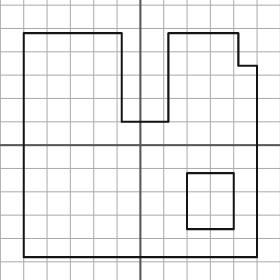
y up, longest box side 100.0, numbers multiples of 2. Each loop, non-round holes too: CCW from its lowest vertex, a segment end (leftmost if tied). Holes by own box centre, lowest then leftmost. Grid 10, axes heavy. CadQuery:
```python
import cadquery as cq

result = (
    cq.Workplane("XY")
    .moveTo(-50.0, -48.0)
    .lineTo(50.0, -48.0)
    .lineTo(50.0, 34.0)
    .lineTo(42.0, 34.0)
    .lineTo(42.0, 48.0)
    .lineTo(12.0, 48.0)
    .lineTo(12.0, 10.0)
    .lineTo(-8.0, 10.0)
    .lineTo(-8.0, 48.0)
    .lineTo(-50.0, 48.0)
    .close()
    .moveTo(20.0, -36.0)
    .lineTo(40.0, -36.0)
    .lineTo(40.0, -12.0)
    .lineTo(20.0, -12.0)
    .close()
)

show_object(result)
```